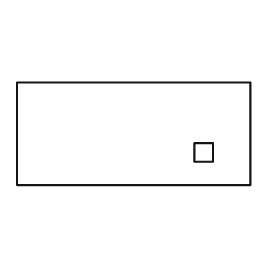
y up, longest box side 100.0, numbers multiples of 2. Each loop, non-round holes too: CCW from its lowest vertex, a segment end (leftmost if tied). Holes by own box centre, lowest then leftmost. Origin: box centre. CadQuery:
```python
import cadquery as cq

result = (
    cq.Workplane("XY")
    .moveTo(-50.0, -22.0)
    .lineTo(50.0, -22.0)
    .lineTo(50.0, 22.0)
    .lineTo(-50.0, 22.0)
    .close()
    .moveTo(26.0, -12.0)
    .lineTo(34.0, -12.0)
    .lineTo(34.0, -4.0)
    .lineTo(26.0, -4.0)
    .close()
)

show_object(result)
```